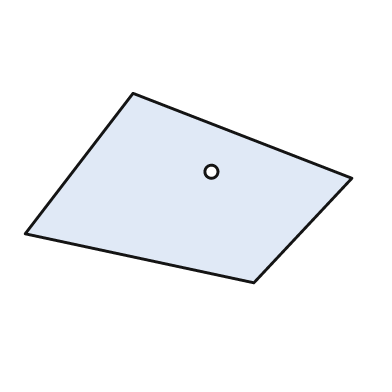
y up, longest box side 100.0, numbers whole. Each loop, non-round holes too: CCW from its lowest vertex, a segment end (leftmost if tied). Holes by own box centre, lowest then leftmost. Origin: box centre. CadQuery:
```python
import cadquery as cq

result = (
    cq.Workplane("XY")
    .moveTo(20.0, -29.0)
    .lineTo(50.0, 3.0)
    .lineTo(-17.0, 29.0)
    .lineTo(-50.0, -14.0)
    .close()
    .moveTo(7.0, 5.0)
    .circle(2.0)
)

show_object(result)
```